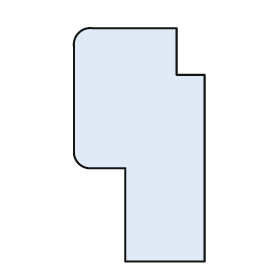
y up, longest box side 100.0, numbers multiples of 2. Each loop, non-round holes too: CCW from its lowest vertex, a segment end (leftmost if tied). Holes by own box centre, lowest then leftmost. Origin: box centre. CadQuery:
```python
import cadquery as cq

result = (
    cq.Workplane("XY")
    .moveTo(-6.0, -50.0)
    .lineTo(28.0, -50.0)
    .lineTo(28.0, 30.0)
    .lineTo(16.0, 30.0)
    .lineTo(16.0, 50.0)
    .lineTo(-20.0, 50.0)
    .threePointArc((-26.0, 48.0), (-28.0, 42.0))
    .lineTo(-28.0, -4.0)
    .threePointArc((-26.0, -8.0), (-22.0, -10.0))
    .lineTo(-6.0, -10.0)
    .close()
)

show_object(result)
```